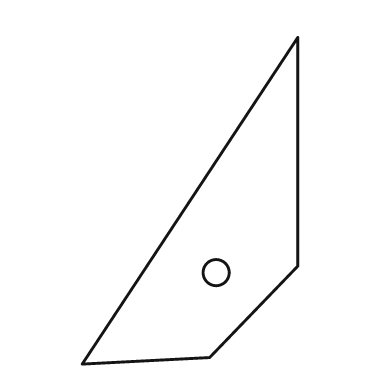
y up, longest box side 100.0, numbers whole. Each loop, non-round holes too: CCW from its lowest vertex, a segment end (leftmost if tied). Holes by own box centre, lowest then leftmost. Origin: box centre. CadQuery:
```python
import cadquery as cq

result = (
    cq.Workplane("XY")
    .moveTo(-33.0, -50.0)
    .lineTo(6.0, -48.0)
    .lineTo(33.0, -20.0)
    .lineTo(33.0, 50.0)
    .close()
    .moveTo(8.0, -22.0)
    .circle(4.0)
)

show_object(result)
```